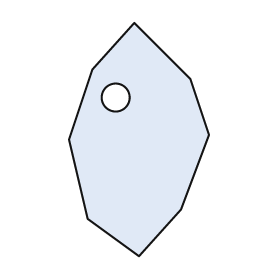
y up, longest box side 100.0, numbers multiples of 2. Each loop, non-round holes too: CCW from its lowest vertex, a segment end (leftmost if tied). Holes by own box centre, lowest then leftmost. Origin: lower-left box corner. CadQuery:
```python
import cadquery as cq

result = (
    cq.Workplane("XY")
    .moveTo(30.0, 0.0)
    .lineTo(48.0, 20.0)
    .lineTo(60.0, 52.0)
    .lineTo(52.0, 76.0)
    .lineTo(28.0, 100.0)
    .lineTo(10.0, 80.0)
    .lineTo(0.0, 50.0)
    .lineTo(8.0, 16.0)
    .close()
    .moveTo(20.0, 68.0)
    .circle(6.0)
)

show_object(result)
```